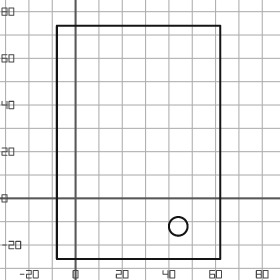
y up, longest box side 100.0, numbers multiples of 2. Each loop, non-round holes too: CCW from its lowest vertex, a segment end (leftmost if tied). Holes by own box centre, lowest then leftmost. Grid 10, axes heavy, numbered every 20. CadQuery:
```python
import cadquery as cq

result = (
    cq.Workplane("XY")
    .moveTo(-8.0, -26.0)
    .lineTo(62.0, -26.0)
    .lineTo(62.0, 74.0)
    .lineTo(-8.0, 74.0)
    .close()
    .moveTo(44.0, -12.0)
    .circle(4.0)
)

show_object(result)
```